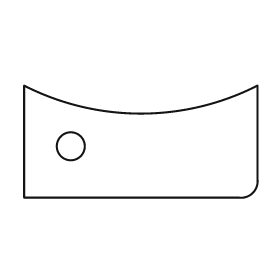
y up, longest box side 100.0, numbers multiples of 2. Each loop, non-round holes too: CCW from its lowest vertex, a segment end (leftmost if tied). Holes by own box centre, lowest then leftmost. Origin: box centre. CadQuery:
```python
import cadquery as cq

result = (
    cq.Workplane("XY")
    .moveTo(-50.0, -24.0)
    .lineTo(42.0, -24.0)
    .threePointArc((48.0, -22.0), (50.0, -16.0))
    .lineTo(50.0, 24.0)
    .threePointArc((0.0, 12.0), (-50.0, 24.0))
    .close()
    .moveTo(-30.0, -2.0)
    .circle(6.0)
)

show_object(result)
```